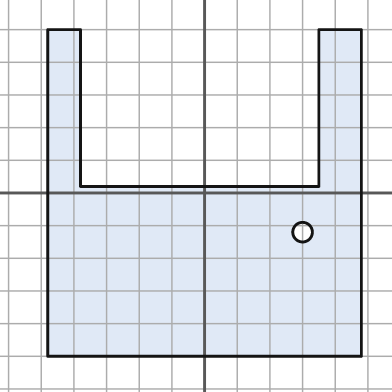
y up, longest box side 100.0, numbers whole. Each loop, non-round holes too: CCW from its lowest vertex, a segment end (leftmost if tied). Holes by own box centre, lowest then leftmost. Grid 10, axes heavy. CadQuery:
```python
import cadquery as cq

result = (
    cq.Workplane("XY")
    .moveTo(-48.0, -50.0)
    .lineTo(48.0, -50.0)
    .lineTo(48.0, 50.0)
    .lineTo(35.0, 50.0)
    .lineTo(35.0, 2.0)
    .lineTo(-38.0, 2.0)
    .lineTo(-38.0, 50.0)
    .lineTo(-48.0, 50.0)
    .close()
    .moveTo(30.0, -12.0)
    .circle(3.0)
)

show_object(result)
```